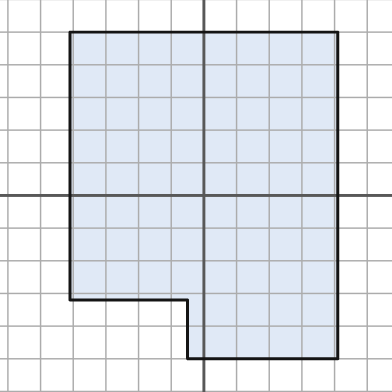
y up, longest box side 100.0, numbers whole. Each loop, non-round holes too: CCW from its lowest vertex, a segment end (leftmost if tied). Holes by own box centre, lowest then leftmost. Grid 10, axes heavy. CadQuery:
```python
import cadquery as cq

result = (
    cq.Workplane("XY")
    .moveTo(-5.0, -50.0)
    .lineTo(41.0, -50.0)
    .lineTo(41.0, 50.0)
    .lineTo(-41.0, 50.0)
    .lineTo(-41.0, -32.0)
    .lineTo(-5.0, -32.0)
    .close()
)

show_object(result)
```